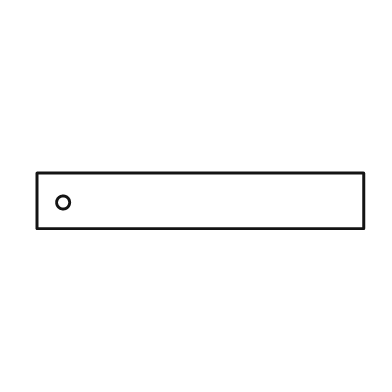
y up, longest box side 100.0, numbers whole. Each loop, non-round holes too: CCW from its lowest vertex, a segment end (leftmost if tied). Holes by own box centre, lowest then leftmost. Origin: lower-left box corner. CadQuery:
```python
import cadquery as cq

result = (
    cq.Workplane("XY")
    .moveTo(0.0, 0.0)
    .lineTo(100.0, 0.0)
    .lineTo(100.0, 17.0)
    .lineTo(0.0, 17.0)
    .close()
    .moveTo(8.0, 8.0)
    .circle(2.0)
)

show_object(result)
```